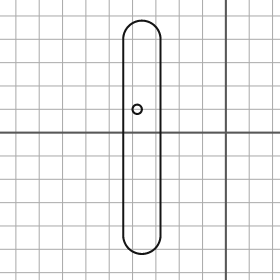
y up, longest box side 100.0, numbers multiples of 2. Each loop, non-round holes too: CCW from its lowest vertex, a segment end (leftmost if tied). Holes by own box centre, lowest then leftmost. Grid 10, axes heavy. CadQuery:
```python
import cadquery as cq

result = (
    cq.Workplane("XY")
    .moveTo(-44.0, -44.0)
    .threePointArc((-36.0, -52.0), (-28.0, -44.0))
    .lineTo(-28.0, 40.0)
    .threePointArc((-36.0, 48.0), (-44.0, 40.0))
    .close()
    .moveTo(-38.0, 10.0)
    .circle(2.0)
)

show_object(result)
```